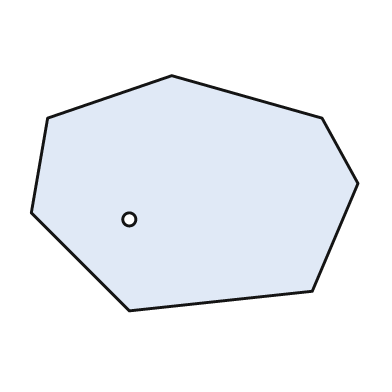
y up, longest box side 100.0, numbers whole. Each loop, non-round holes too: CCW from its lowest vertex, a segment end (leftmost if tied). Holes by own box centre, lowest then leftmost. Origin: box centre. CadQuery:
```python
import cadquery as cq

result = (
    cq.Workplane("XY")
    .moveTo(-20.0, -36.0)
    .lineTo(36.0, -30.0)
    .lineTo(50.0, 3.0)
    .lineTo(39.0, 23.0)
    .lineTo(-7.0, 36.0)
    .lineTo(-45.0, 23.0)
    .lineTo(-50.0, -6.0)
    .close()
    .moveTo(-20.0, -8.0)
    .circle(2.0)
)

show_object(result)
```